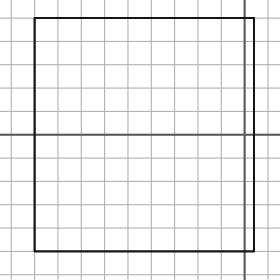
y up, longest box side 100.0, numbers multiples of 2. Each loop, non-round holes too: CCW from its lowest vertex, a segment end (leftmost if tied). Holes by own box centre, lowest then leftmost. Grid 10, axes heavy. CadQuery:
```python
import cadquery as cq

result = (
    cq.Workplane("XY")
    .moveTo(-90.0, -50.0)
    .lineTo(4.0, -50.0)
    .lineTo(4.0, 50.0)
    .lineTo(-90.0, 50.0)
    .close()
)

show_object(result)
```